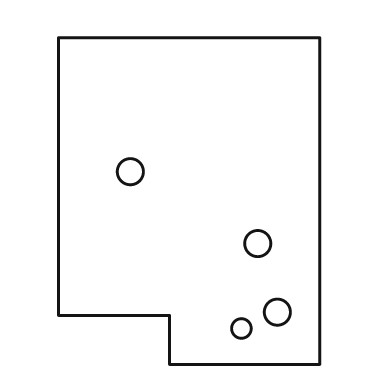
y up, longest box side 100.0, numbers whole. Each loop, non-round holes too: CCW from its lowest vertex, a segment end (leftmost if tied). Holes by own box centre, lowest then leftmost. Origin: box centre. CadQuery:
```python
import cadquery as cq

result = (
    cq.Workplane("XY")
    .moveTo(-6.0, -50.0)
    .lineTo(40.0, -50.0)
    .lineTo(40.0, 50.0)
    .lineTo(-40.0, 50.0)
    .lineTo(-40.0, -35.0)
    .lineTo(-6.0, -35.0)
    .close()
    .moveTo(16.0, -39.0)
    .circle(3.0)
    .moveTo(27.0, -34.0)
    .circle(4.0)
    .moveTo(21.0, -13.0)
    .circle(4.0)
    .moveTo(-18.0, 9.0)
    .circle(4.0)
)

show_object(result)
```